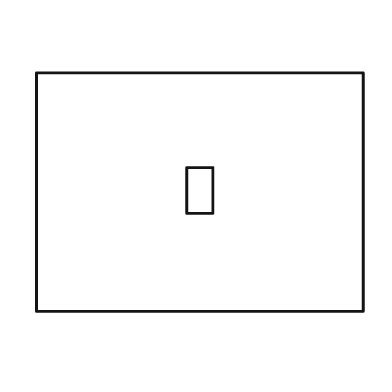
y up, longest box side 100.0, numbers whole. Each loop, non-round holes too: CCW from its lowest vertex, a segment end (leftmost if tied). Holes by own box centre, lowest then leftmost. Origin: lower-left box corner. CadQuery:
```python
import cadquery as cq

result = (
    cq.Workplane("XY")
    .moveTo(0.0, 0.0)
    .lineTo(100.0, 0.0)
    .lineTo(100.0, 73.0)
    .lineTo(0.0, 73.0)
    .close()
    .moveTo(46.0, 30.0)
    .lineTo(54.0, 30.0)
    .lineTo(54.0, 44.0)
    .lineTo(46.0, 44.0)
    .close()
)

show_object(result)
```